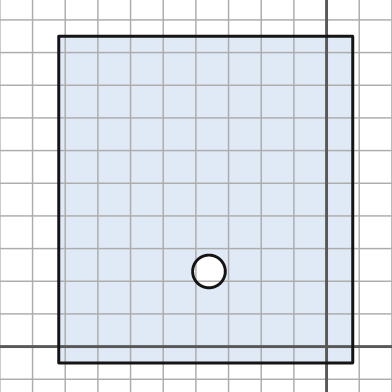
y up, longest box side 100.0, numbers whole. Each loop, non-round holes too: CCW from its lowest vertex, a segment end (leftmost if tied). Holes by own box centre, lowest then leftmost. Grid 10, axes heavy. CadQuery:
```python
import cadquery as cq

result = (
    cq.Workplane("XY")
    .moveTo(-82.0, -5.0)
    .lineTo(8.0, -5.0)
    .lineTo(8.0, 95.0)
    .lineTo(-82.0, 95.0)
    .close()
    .moveTo(-36.0, 23.0)
    .circle(5.0)
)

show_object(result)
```